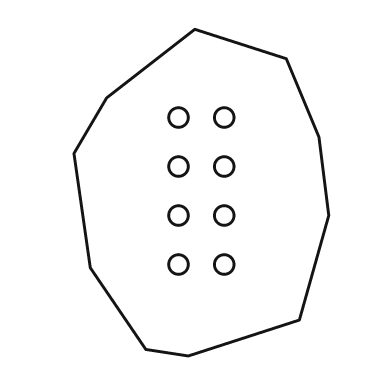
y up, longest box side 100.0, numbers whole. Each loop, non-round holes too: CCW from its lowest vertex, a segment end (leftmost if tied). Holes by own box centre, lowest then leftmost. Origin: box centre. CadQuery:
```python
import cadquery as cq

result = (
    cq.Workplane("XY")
    .moveTo(-4.0, -50.0)
    .lineTo(30.0, -39.0)
    .lineTo(39.0, -7.0)
    .lineTo(36.0, 17.0)
    .lineTo(26.0, 41.0)
    .lineTo(-2.0, 50.0)
    .lineTo(-29.0, 29.0)
    .lineTo(-39.0, 12.0)
    .lineTo(-34.0, -23.0)
    .lineTo(-17.0, -48.0)
    .close()
    .moveTo(-7.0, -22.0)
    .circle(3.0)
    .moveTo(7.0, -22.0)
    .circle(3.0)
    .moveTo(-7.0, -7.0)
    .circle(3.0)
    .moveTo(7.0, -7.0)
    .circle(3.0)
    .moveTo(-7.0, 8.0)
    .circle(3.0)
    .moveTo(7.0, 8.0)
    .circle(3.0)
    .moveTo(-7.0, 23.0)
    .circle(3.0)
    .moveTo(7.0, 23.0)
    .circle(3.0)
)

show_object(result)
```